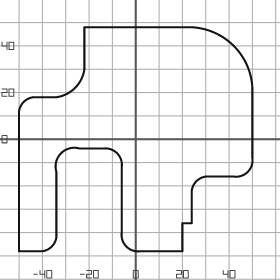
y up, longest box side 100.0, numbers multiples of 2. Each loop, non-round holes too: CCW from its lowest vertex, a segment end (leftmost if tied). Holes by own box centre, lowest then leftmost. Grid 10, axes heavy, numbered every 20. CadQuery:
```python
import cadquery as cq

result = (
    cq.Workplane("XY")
    .moveTo(-50.0, -48.0)
    .lineTo(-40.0, -48.0)
    .threePointArc((-36.0, -46.0), (-34.0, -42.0))
    .lineTo(-34.0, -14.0)
    .threePointArc((-32.0, -6.0), (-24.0, -4.0))
    .lineTo(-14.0, -4.0)
    .threePointArc((-8.0, -6.0), (-6.0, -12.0))
    .lineTo(-6.0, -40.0)
    .threePointArc((-4.0, -46.0), (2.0, -48.0))
    .lineTo(20.0, -48.0)
    .lineTo(20.0, -36.0)
    .lineTo(24.0, -36.0)
    .lineTo(24.0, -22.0)
    .threePointArc((26.0, -18.0), (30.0, -16.0))
    .lineTo(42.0, -16.0)
    .threePointArc((48.0, -14.0), (50.0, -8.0))
    .lineTo(50.0, 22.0)
    .threePointArc((42.0, 40.0), (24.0, 48.0))
    .lineTo(-22.0, 48.0)
    .lineTo(-22.0, 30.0)
    .threePointArc((-26.0, 22.0), (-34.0, 18.0))
    .lineTo(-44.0, 18.0)
    .threePointArc((-48.0, 16.0), (-50.0, 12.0))
    .close()
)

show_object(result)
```